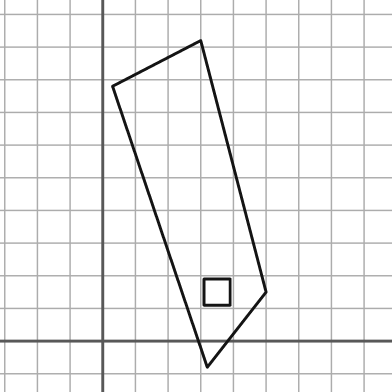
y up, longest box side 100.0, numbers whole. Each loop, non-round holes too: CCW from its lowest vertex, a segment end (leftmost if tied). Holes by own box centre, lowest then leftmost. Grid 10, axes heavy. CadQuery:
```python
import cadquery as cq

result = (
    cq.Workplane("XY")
    .moveTo(32.0, -8.0)
    .lineTo(50.0, 15.0)
    .lineTo(30.0, 92.0)
    .lineTo(3.0, 78.0)
    .close()
    .moveTo(31.0, 11.0)
    .lineTo(39.0, 11.0)
    .lineTo(39.0, 19.0)
    .lineTo(31.0, 19.0)
    .close()
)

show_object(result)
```